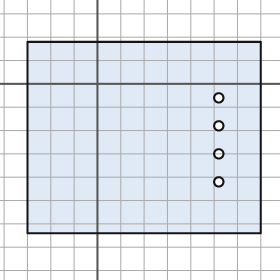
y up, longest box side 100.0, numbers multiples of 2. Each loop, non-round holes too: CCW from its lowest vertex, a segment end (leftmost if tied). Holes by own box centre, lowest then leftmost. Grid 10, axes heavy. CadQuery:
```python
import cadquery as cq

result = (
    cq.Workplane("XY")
    .moveTo(-30.0, -64.0)
    .lineTo(70.0, -64.0)
    .lineTo(70.0, 18.0)
    .lineTo(-30.0, 18.0)
    .close()
    .moveTo(52.0, -42.0)
    .circle(2.0)
    .moveTo(52.0, -30.0)
    .circle(2.0)
    .moveTo(52.0, -18.0)
    .circle(2.0)
    .moveTo(52.0, -6.0)
    .circle(2.0)
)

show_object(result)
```